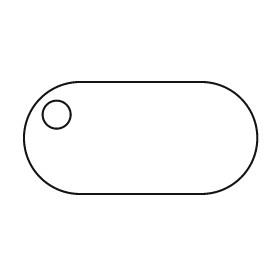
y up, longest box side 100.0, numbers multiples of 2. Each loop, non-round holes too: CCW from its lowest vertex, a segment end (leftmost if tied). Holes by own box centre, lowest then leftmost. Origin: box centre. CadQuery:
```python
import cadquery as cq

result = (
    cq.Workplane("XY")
    .moveTo(-26.0, -24.0)
    .lineTo(26.0, -24.0)
    .threePointArc((50.0, 0.0), (26.0, 24.0))
    .lineTo(-26.0, 24.0)
    .threePointArc((-50.0, 0.0), (-26.0, -24.0))
    .close()
    .moveTo(-36.0, 10.0)
    .circle(6.0)
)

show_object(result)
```